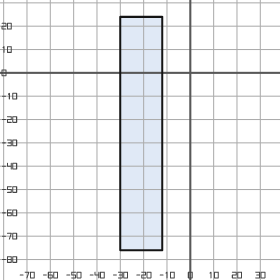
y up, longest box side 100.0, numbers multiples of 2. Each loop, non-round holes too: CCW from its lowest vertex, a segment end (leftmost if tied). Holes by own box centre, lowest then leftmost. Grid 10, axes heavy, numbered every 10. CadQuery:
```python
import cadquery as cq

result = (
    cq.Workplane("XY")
    .moveTo(-30.0, -76.0)
    .lineTo(-12.0, -76.0)
    .lineTo(-12.0, 24.0)
    .lineTo(-30.0, 24.0)
    .close()
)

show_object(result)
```